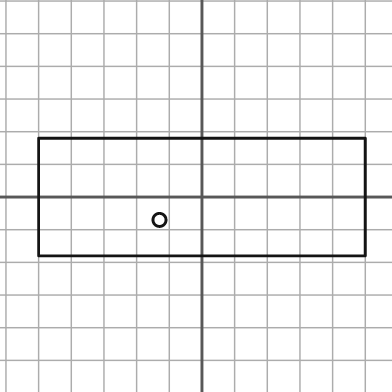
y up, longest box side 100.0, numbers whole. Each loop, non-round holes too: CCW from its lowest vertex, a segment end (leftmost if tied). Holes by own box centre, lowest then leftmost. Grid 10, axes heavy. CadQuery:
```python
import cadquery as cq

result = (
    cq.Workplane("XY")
    .moveTo(-50.0, -18.0)
    .lineTo(50.0, -18.0)
    .lineTo(50.0, 18.0)
    .lineTo(-50.0, 18.0)
    .close()
    .moveTo(-13.0, -7.0)
    .circle(2.0)
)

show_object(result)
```